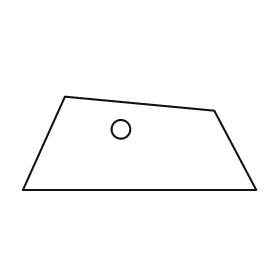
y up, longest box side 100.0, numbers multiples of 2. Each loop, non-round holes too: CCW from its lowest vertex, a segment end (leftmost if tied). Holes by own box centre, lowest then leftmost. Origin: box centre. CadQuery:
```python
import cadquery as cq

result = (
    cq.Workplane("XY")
    .moveTo(-50.0, -20.0)
    .lineTo(50.0, -20.0)
    .lineTo(32.0, 14.0)
    .lineTo(-32.0, 20.0)
    .close()
    .moveTo(-8.0, 6.0)
    .circle(4.0)
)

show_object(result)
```